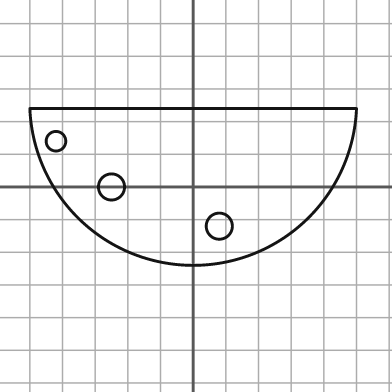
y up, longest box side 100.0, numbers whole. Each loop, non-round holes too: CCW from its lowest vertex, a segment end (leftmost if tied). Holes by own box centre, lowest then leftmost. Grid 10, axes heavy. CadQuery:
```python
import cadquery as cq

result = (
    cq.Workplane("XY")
    .moveTo(-50.0, 24.0)
    .threePointArc((0.0, -24.0), (50.0, 24.0))
    .close()
    .moveTo(8.0, -12.0)
    .circle(4.0)
    .moveTo(-25.0, 0.0)
    .circle(4.0)
    .moveTo(-42.0, 14.0)
    .circle(3.0)
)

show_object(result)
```